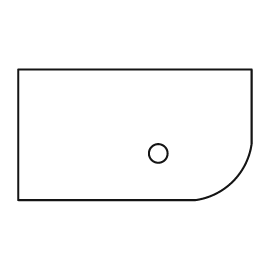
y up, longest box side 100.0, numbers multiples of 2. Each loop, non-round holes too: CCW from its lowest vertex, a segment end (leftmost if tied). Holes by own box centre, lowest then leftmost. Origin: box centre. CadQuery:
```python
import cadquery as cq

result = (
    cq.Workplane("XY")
    .moveTo(-50.0, -28.0)
    .lineTo(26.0, -28.0)
    .threePointArc((42.0, -20.0), (50.0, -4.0))
    .lineTo(50.0, 28.0)
    .lineTo(-50.0, 28.0)
    .close()
    .moveTo(10.0, -8.0)
    .circle(4.0)
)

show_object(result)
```